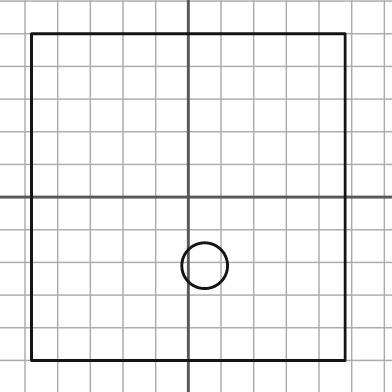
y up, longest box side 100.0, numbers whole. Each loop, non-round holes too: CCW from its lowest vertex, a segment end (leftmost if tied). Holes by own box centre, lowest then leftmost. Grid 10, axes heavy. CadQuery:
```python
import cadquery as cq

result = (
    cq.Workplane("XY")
    .moveTo(-48.0, -50.0)
    .lineTo(48.0, -50.0)
    .lineTo(48.0, 50.0)
    .lineTo(-48.0, 50.0)
    .close()
    .moveTo(5.0, -21.0)
    .circle(7.0)
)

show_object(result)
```